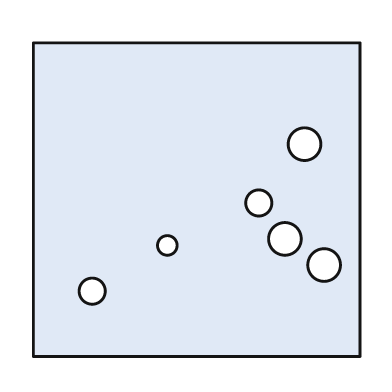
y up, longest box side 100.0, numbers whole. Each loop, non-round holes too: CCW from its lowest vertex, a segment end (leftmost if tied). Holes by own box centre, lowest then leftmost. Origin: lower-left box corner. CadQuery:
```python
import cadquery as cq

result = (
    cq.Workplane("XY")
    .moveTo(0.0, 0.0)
    .lineTo(100.0, 0.0)
    .lineTo(100.0, 96.0)
    .lineTo(0.0, 96.0)
    .close()
    .moveTo(18.0, 20.0)
    .circle(4.0)
    .moveTo(89.0, 28.0)
    .circle(5.0)
    .moveTo(41.0, 34.0)
    .circle(3.0)
    .moveTo(77.0, 36.0)
    .circle(5.0)
    .moveTo(69.0, 47.0)
    .circle(4.0)
    .moveTo(83.0, 65.0)
    .circle(5.0)
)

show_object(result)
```